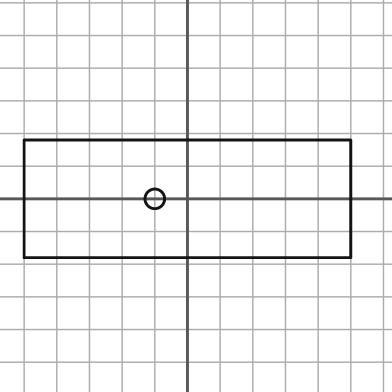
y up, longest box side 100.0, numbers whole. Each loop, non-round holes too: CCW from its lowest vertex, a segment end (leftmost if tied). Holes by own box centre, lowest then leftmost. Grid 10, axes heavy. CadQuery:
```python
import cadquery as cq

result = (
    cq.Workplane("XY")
    .moveTo(-50.0, -18.0)
    .lineTo(50.0, -18.0)
    .lineTo(50.0, 18.0)
    .lineTo(-50.0, 18.0)
    .close()
    .moveTo(-10.0, 0.0)
    .circle(3.0)
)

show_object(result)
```